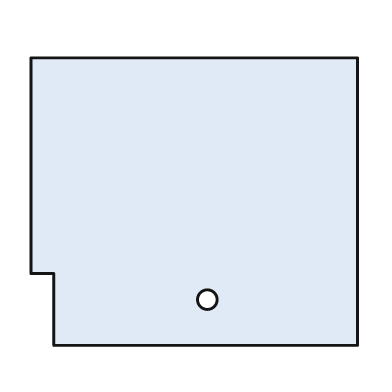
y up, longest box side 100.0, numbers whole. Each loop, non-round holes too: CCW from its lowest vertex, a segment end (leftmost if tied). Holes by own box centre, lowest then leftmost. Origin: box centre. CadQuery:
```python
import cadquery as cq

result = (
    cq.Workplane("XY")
    .moveTo(-43.0, -44.0)
    .lineTo(50.0, -44.0)
    .lineTo(50.0, 44.0)
    .lineTo(-50.0, 44.0)
    .lineTo(-50.0, -22.0)
    .lineTo(-43.0, -22.0)
    .close()
    .moveTo(4.0, -30.0)
    .circle(3.0)
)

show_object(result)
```